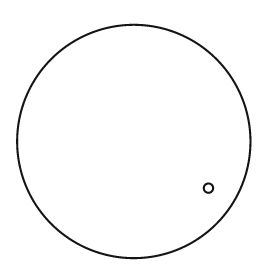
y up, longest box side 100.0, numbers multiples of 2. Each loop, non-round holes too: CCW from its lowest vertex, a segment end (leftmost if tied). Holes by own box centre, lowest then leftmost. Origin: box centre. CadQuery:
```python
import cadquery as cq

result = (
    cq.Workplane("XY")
    .moveTo(0.0, 0.0)
    .circle(50.0)
    .moveTo(32.0, -20.0)
    .circle(2.0)
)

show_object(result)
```